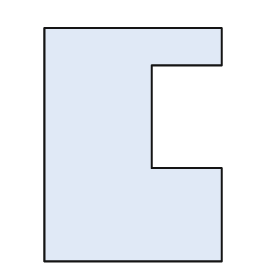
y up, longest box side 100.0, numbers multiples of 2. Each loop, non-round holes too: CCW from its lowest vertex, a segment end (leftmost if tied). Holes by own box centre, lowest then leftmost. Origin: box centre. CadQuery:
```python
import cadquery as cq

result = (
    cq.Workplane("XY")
    .moveTo(-38.0, -50.0)
    .lineTo(38.0, -50.0)
    .lineTo(38.0, -10.0)
    .lineTo(8.0, -10.0)
    .lineTo(8.0, 34.0)
    .lineTo(38.0, 34.0)
    .lineTo(38.0, 50.0)
    .lineTo(-38.0, 50.0)
    .close()
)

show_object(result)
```